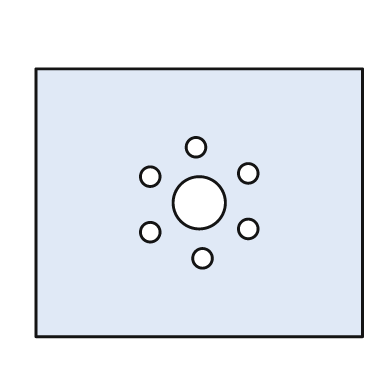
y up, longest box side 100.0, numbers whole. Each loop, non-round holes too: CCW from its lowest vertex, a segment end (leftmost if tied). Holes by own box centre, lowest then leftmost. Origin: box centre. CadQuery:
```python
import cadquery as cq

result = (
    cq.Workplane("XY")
    .moveTo(-50.0, -41.0)
    .lineTo(50.0, -41.0)
    .lineTo(50.0, 41.0)
    .lineTo(-50.0, 41.0)
    .close()
    .moveTo(1.0, -17.0)
    .circle(3.0)
    .moveTo(-15.0, -9.0)
    .circle(3.0)
    .moveTo(15.0, -8.0)
    .circle(3.0)
    .moveTo(0.0, 0.0)
    .circle(8.0)
    .moveTo(-15.0, 8.0)
    .circle(3.0)
    .moveTo(15.0, 9.0)
    .circle(3.0)
    .moveTo(-1.0, 17.0)
    .circle(3.0)
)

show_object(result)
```